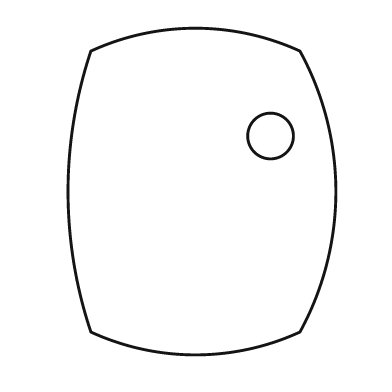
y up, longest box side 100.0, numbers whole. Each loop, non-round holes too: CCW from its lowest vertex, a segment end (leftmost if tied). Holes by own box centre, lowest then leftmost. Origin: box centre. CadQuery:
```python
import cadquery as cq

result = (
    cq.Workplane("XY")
    .moveTo(-34.0, -43.0)
    .threePointArc((-2.0, -50.0), (30.0, -43.0))
    .threePointArc((41.0, 0.0), (30.0, 43.0))
    .threePointArc((-2.0, 50.0), (-34.0, 43.0))
    .threePointArc((-41.0, 0.0), (-34.0, -43.0))
    .close()
    .moveTo(21.0, 17.0)
    .circle(7.0)
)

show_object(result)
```